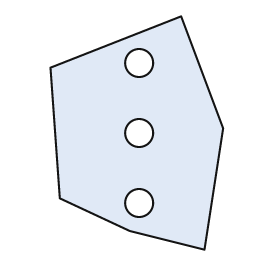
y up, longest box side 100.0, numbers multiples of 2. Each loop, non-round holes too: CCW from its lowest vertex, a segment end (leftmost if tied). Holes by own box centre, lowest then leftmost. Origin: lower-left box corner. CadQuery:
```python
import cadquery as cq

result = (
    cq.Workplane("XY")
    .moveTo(66.0, 0.0)
    .lineTo(74.0, 52.0)
    .lineTo(56.0, 100.0)
    .lineTo(0.0, 78.0)
    .lineTo(4.0, 22.0)
    .lineTo(34.0, 8.0)
    .close()
    .moveTo(38.0, 20.0)
    .circle(6.0)
    .moveTo(38.0, 50.0)
    .circle(6.0)
    .moveTo(38.0, 80.0)
    .circle(6.0)
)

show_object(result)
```